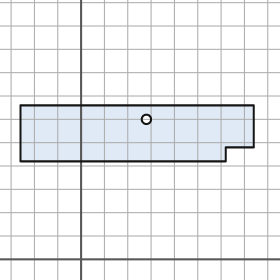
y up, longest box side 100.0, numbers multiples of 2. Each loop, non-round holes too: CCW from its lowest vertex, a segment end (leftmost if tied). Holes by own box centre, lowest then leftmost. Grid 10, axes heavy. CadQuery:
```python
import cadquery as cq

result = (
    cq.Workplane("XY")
    .moveTo(-26.0, 42.0)
    .lineTo(62.0, 42.0)
    .lineTo(62.0, 48.0)
    .lineTo(74.0, 48.0)
    .lineTo(74.0, 66.0)
    .lineTo(-26.0, 66.0)
    .close()
    .moveTo(28.0, 60.0)
    .circle(2.0)
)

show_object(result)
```